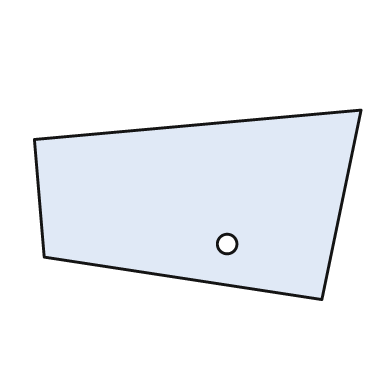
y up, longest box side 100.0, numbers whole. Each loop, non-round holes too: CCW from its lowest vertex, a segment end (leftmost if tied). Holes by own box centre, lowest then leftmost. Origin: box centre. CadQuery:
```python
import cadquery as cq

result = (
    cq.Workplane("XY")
    .moveTo(38.0, -29.0)
    .lineTo(50.0, 29.0)
    .lineTo(-50.0, 20.0)
    .lineTo(-47.0, -16.0)
    .close()
    .moveTo(9.0, -12.0)
    .circle(3.0)
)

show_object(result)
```